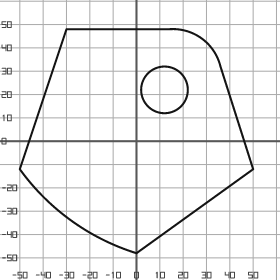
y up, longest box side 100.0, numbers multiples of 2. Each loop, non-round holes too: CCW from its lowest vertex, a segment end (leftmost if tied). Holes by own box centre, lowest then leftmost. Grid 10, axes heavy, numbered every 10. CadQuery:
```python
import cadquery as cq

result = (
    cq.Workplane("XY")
    .moveTo(0.0, -48.0)
    .lineTo(50.0, -12.0)
    .lineTo(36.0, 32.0)
    .threePointArc((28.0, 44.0), (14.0, 48.0))
    .lineTo(-30.0, 48.0)
    .lineTo(-50.0, -12.0)
    .threePointArc((-28.0, -34.0), (0.0, -48.0))
    .close()
    .moveTo(12.0, 22.0)
    .circle(10.0)
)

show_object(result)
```